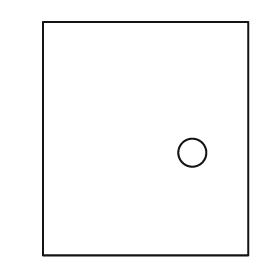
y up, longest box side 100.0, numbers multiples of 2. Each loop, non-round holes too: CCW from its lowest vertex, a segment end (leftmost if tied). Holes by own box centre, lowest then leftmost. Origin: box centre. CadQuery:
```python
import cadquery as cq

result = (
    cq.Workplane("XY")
    .moveTo(-44.0, -50.0)
    .lineTo(44.0, -50.0)
    .lineTo(44.0, 50.0)
    .lineTo(-44.0, 50.0)
    .close()
    .moveTo(20.0, -6.0)
    .circle(6.0)
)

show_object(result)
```